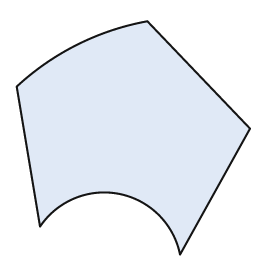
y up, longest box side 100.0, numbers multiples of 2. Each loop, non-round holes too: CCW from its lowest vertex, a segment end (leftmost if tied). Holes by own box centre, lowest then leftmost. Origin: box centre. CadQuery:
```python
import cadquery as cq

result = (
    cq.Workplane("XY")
    .moveTo(20.0, -50.0)
    .lineTo(50.0, 4.0)
    .lineTo(6.0, 50.0)
    .threePointArc((-24.0, 40.0), (-50.0, 22.0))
    .lineTo(-40.0, -38.0)
    .threePointArc((-6.0, -24.0), (20.0, -50.0))
    .close()
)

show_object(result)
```